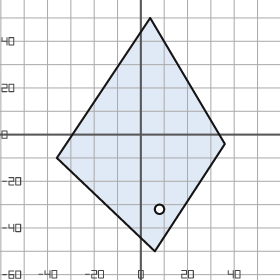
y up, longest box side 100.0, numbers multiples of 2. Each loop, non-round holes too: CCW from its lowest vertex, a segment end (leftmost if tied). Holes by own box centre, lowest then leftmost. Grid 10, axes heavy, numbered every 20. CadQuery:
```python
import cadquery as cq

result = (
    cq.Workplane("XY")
    .moveTo(6.0, -50.0)
    .lineTo(36.0, -4.0)
    .lineTo(4.0, 50.0)
    .lineTo(-36.0, -10.0)
    .close()
    .moveTo(8.0, -32.0)
    .circle(2.0)
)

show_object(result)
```